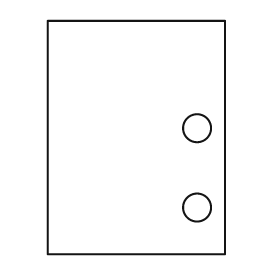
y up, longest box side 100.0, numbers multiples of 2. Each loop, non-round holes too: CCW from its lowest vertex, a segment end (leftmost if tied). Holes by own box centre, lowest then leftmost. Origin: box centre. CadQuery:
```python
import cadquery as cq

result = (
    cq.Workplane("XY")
    .moveTo(-38.0, -50.0)
    .lineTo(38.0, -50.0)
    .lineTo(38.0, 50.0)
    .lineTo(-38.0, 50.0)
    .close()
    .moveTo(26.0, -30.0)
    .circle(6.0)
    .moveTo(26.0, 4.0)
    .circle(6.0)
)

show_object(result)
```